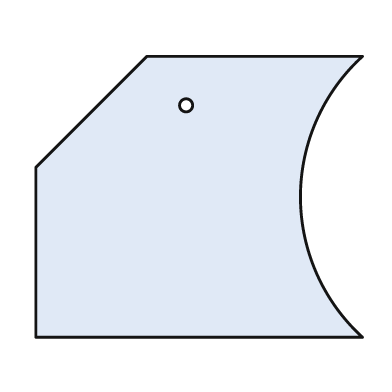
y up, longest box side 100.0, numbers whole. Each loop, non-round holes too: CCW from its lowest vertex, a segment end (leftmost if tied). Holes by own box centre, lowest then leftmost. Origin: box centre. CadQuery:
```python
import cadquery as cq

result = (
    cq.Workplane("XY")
    .moveTo(-50.0, -43.0)
    .lineTo(50.0, -43.0)
    .threePointArc((31.0, 0.0), (50.0, 43.0))
    .lineTo(-16.0, 43.0)
    .lineTo(-50.0, 9.0)
    .close()
    .moveTo(-4.0, 28.0)
    .circle(2.0)
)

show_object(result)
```